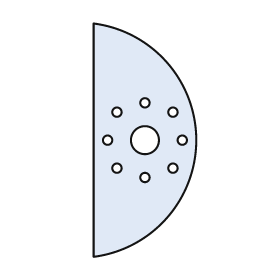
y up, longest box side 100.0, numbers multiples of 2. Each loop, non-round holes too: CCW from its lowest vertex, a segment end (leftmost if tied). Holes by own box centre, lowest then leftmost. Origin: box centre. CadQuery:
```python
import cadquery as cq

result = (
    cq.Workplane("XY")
    .moveTo(-22.0, -50.0)
    .threePointArc((22.0, 0.0), (-22.0, 50.0))
    .close()
    .moveTo(0.0, -16.0)
    .circle(2.0)
    .moveTo(-12.0, -12.0)
    .circle(2.0)
    .moveTo(12.0, -12.0)
    .circle(2.0)
    .moveTo(-16.0, 0.0)
    .circle(2.0)
    .moveTo(0.0, 0.0)
    .circle(6.0)
    .moveTo(16.0, 0.0)
    .circle(2.0)
    .moveTo(-12.0, 12.0)
    .circle(2.0)
    .moveTo(12.0, 12.0)
    .circle(2.0)
    .moveTo(0.0, 16.0)
    .circle(2.0)
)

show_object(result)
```